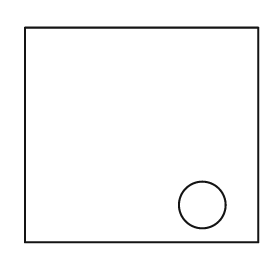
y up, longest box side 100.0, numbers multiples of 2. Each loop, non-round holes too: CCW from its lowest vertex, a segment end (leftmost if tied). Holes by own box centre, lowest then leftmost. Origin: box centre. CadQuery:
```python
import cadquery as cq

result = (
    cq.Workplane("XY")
    .moveTo(-50.0, -46.0)
    .lineTo(50.0, -46.0)
    .lineTo(50.0, 46.0)
    .lineTo(-50.0, 46.0)
    .close()
    .moveTo(26.0, -30.0)
    .circle(10.0)
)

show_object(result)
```